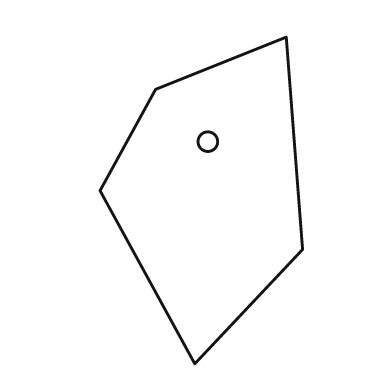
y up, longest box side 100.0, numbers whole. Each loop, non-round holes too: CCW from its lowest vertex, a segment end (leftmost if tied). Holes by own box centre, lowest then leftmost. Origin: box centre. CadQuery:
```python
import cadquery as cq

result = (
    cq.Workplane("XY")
    .moveTo(-2.0, -50.0)
    .lineTo(31.0, -15.0)
    .lineTo(26.0, 50.0)
    .lineTo(-14.0, 34.0)
    .lineTo(-31.0, 3.0)
    .close()
    .moveTo(2.0, 18.0)
    .circle(3.0)
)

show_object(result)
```